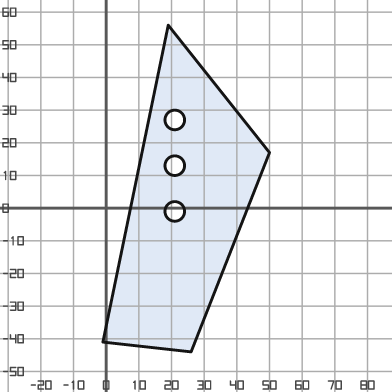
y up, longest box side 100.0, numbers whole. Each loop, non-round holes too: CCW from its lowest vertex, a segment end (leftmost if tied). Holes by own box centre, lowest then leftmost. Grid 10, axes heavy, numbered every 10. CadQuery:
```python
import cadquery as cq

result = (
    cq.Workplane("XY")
    .moveTo(26.0, -44.0)
    .lineTo(50.0, 17.0)
    .lineTo(19.0, 56.0)
    .lineTo(-1.0, -41.0)
    .close()
    .moveTo(21.0, -1.0)
    .circle(3.0)
    .moveTo(21.0, 13.0)
    .circle(3.0)
    .moveTo(21.0, 27.0)
    .circle(3.0)
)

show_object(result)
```